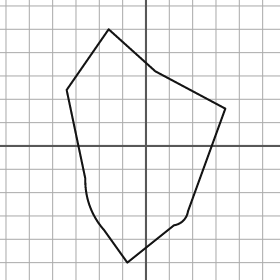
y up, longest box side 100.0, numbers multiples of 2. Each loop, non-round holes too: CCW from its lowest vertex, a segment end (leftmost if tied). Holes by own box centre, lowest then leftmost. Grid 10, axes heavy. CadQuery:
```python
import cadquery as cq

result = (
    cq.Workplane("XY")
    .moveTo(-8.0, -50.0)
    .lineTo(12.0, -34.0)
    .threePointArc((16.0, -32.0), (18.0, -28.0))
    .lineTo(34.0, 16.0)
    .lineTo(4.0, 32.0)
    .lineTo(-16.0, 50.0)
    .lineTo(-34.0, 24.0)
    .lineTo(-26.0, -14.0)
    .threePointArc((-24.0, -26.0), (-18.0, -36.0))
    .close()
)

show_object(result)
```